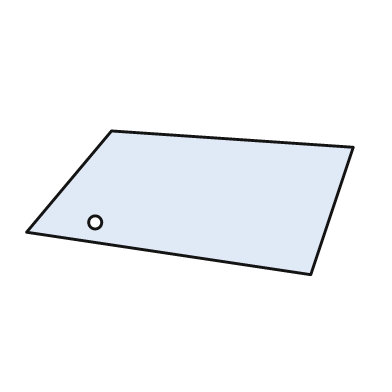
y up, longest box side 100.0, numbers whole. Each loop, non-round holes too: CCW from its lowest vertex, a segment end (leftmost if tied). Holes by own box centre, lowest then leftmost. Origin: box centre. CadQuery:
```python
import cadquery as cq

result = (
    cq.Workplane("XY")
    .moveTo(37.0, -22.0)
    .lineTo(50.0, 17.0)
    .lineTo(-24.0, 22.0)
    .lineTo(-50.0, -9.0)
    .close()
    .moveTo(-29.0, -6.0)
    .circle(2.0)
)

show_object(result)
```